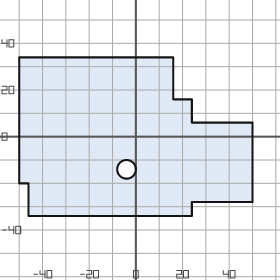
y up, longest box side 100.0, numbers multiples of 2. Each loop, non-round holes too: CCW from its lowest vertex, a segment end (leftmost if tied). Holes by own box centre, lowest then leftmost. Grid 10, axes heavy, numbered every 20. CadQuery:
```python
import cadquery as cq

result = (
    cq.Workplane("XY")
    .moveTo(-46.0, -34.0)
    .lineTo(24.0, -34.0)
    .lineTo(24.0, -28.0)
    .lineTo(50.0, -28.0)
    .lineTo(50.0, 6.0)
    .lineTo(24.0, 6.0)
    .lineTo(24.0, 16.0)
    .lineTo(16.0, 16.0)
    .lineTo(16.0, 34.0)
    .lineTo(-50.0, 34.0)
    .lineTo(-50.0, -20.0)
    .lineTo(-46.0, -20.0)
    .close()
    .moveTo(-4.0, -14.0)
    .circle(4.0)
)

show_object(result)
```